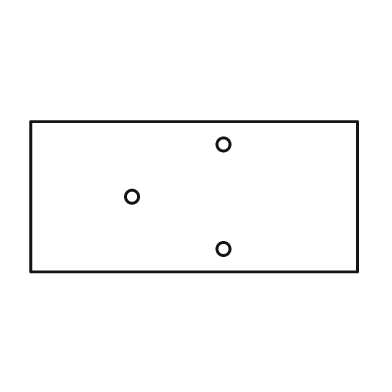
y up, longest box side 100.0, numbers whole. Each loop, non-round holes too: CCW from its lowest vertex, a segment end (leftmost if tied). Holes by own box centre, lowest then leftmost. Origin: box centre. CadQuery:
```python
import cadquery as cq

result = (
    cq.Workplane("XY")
    .moveTo(-50.0, -23.0)
    .lineTo(50.0, -23.0)
    .lineTo(50.0, 23.0)
    .lineTo(-50.0, 23.0)
    .close()
    .moveTo(9.0, -16.0)
    .circle(2.0)
    .moveTo(-19.0, 0.0)
    .circle(2.0)
    .moveTo(9.0, 16.0)
    .circle(2.0)
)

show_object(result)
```